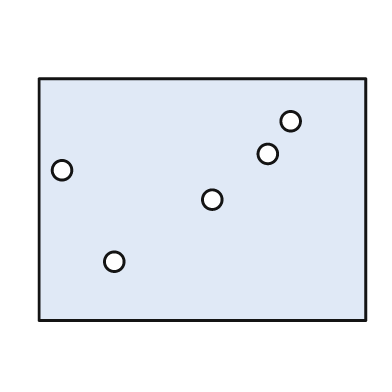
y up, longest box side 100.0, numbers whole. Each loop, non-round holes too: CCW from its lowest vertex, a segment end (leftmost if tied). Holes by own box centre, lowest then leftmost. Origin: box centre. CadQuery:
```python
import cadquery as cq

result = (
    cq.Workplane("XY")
    .moveTo(-50.0, -37.0)
    .lineTo(50.0, -37.0)
    .lineTo(50.0, 37.0)
    .lineTo(-50.0, 37.0)
    .close()
    .moveTo(-27.0, -19.0)
    .circle(3.0)
    .moveTo(3.0, 0.0)
    .circle(3.0)
    .moveTo(-43.0, 9.0)
    .circle(3.0)
    .moveTo(20.0, 14.0)
    .circle(3.0)
    .moveTo(27.0, 24.0)
    .circle(3.0)
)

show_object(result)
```